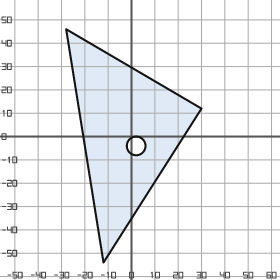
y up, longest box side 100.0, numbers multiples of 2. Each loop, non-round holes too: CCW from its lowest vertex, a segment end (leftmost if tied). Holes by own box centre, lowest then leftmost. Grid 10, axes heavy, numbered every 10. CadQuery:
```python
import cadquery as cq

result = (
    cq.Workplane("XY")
    .moveTo(-12.0, -54.0)
    .lineTo(30.0, 12.0)
    .lineTo(-28.0, 46.0)
    .close()
    .moveTo(2.0, -4.0)
    .circle(4.0)
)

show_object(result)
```